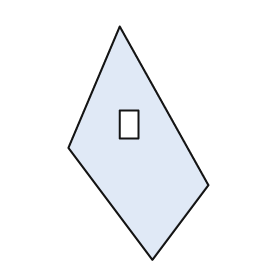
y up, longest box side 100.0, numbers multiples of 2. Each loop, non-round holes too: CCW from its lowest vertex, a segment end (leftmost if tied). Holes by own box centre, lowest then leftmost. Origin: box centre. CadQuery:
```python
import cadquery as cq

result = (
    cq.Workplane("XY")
    .moveTo(6.0, -50.0)
    .lineTo(30.0, -18.0)
    .lineTo(-8.0, 50.0)
    .lineTo(-30.0, -2.0)
    .close()
    .moveTo(-8.0, 2.0)
    .lineTo(0.0, 2.0)
    .lineTo(0.0, 14.0)
    .lineTo(-8.0, 14.0)
    .close()
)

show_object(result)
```